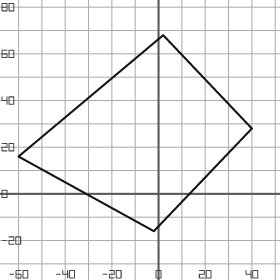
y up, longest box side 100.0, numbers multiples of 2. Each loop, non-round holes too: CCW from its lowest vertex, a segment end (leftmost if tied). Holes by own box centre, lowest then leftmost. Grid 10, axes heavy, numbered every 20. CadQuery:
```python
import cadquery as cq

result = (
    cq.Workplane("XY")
    .moveTo(-2.0, -16.0)
    .lineTo(40.0, 28.0)
    .lineTo(2.0, 68.0)
    .lineTo(-60.0, 16.0)
    .close()
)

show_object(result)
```